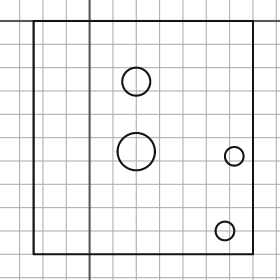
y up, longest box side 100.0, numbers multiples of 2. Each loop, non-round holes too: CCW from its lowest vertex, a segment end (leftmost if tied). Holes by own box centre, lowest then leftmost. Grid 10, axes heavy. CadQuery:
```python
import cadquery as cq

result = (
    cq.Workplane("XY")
    .moveTo(-24.0, -100.0)
    .lineTo(70.0, -100.0)
    .lineTo(70.0, 0.0)
    .lineTo(-24.0, 0.0)
    .close()
    .moveTo(58.0, -90.0)
    .circle(4.0)
    .moveTo(62.0, -58.0)
    .circle(4.0)
    .moveTo(20.0, -56.0)
    .circle(8.0)
    .moveTo(20.0, -26.0)
    .circle(6.0)
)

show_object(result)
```